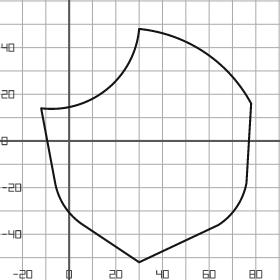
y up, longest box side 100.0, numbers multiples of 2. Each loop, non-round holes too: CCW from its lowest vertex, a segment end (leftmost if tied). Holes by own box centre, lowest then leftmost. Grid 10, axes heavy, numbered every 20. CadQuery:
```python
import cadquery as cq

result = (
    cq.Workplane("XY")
    .moveTo(30.0, -52.0)
    .lineTo(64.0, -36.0)
    .threePointArc((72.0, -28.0), (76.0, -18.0))
    .lineTo(78.0, 16.0)
    .threePointArc((58.0, 38.0), (30.0, 48.0))
    .threePointArc((16.0, 22.0), (-12.0, 14.0))
    .lineTo(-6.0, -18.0)
    .threePointArc((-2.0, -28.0), (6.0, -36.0))
    .close()
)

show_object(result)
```